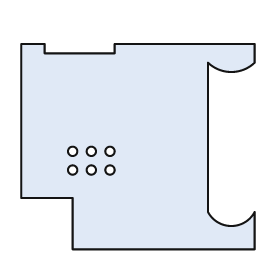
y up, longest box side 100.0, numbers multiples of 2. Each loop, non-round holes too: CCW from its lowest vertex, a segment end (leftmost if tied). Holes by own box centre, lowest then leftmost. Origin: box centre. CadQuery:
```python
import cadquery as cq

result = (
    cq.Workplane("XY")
    .moveTo(-28.0, -44.0)
    .lineTo(50.0, -44.0)
    .lineTo(50.0, -28.0)
    .threePointArc((40.0, -34.0), (30.0, -28.0))
    .lineTo(30.0, 36.0)
    .threePointArc((40.0, 32.0), (50.0, 36.0))
    .lineTo(50.0, 44.0)
    .lineTo(-10.0, 44.0)
    .lineTo(-10.0, 40.0)
    .lineTo(-40.0, 40.0)
    .lineTo(-40.0, 44.0)
    .lineTo(-50.0, 44.0)
    .lineTo(-50.0, -22.0)
    .lineTo(-28.0, -22.0)
    .close()
    .moveTo(-28.0, -10.0)
    .circle(2.0)
    .moveTo(-20.0, -10.0)
    .circle(2.0)
    .moveTo(-12.0, -10.0)
    .circle(2.0)
    .moveTo(-28.0, -2.0)
    .circle(2.0)
    .moveTo(-20.0, -2.0)
    .circle(2.0)
    .moveTo(-12.0, -2.0)
    .circle(2.0)
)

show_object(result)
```